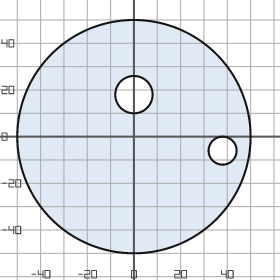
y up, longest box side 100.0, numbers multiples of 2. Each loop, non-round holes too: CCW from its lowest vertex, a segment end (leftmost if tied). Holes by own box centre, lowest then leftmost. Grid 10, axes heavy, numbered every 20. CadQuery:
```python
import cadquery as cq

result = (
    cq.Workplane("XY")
    .moveTo(0.0, 0.0)
    .circle(50.0)
    .moveTo(38.0, -6.0)
    .circle(6.0)
    .moveTo(0.0, 18.0)
    .circle(8.0)
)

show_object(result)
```